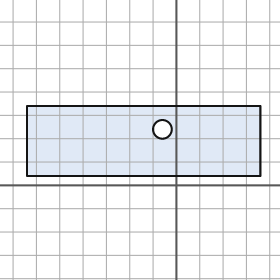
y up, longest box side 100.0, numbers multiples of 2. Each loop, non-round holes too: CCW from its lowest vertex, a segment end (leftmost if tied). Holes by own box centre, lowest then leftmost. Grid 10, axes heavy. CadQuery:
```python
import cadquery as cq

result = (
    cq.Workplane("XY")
    .moveTo(-64.0, 4.0)
    .lineTo(36.0, 4.0)
    .lineTo(36.0, 34.0)
    .lineTo(-64.0, 34.0)
    .close()
    .moveTo(-6.0, 24.0)
    .circle(4.0)
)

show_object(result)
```